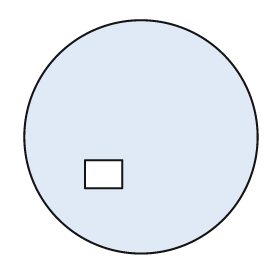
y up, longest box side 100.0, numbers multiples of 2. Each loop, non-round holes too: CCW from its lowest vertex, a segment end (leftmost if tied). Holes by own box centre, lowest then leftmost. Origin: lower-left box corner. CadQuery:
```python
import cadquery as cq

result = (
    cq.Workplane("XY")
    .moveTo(50.0, 50.0)
    .circle(50.0)
    .moveTo(26.0, 28.0)
    .lineTo(42.0, 28.0)
    .lineTo(42.0, 40.0)
    .lineTo(26.0, 40.0)
    .close()
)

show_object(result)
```